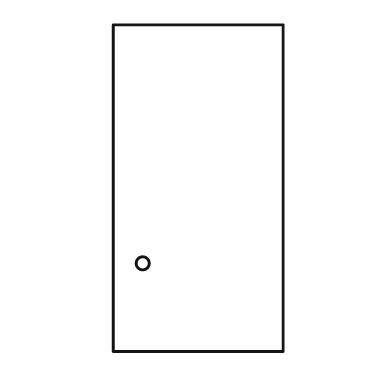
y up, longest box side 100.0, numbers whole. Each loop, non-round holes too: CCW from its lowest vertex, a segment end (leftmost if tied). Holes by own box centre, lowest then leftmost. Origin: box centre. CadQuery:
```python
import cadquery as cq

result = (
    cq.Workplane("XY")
    .moveTo(-26.0, -50.0)
    .lineTo(26.0, -50.0)
    .lineTo(26.0, 50.0)
    .lineTo(-26.0, 50.0)
    .close()
    .moveTo(-17.0, -23.0)
    .circle(2.0)
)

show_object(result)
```